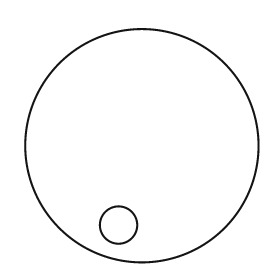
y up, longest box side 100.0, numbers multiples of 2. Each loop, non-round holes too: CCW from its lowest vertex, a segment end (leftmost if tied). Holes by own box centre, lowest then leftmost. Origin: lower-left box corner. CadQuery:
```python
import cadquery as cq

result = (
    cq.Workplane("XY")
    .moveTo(50.0, 50.0)
    .circle(50.0)
    .moveTo(40.0, 16.0)
    .circle(8.0)
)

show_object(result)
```